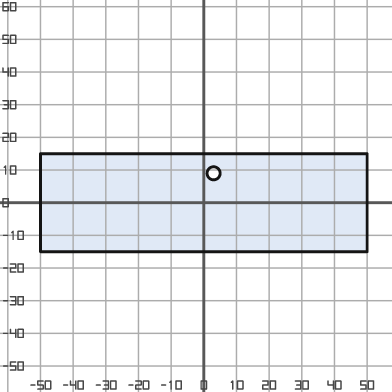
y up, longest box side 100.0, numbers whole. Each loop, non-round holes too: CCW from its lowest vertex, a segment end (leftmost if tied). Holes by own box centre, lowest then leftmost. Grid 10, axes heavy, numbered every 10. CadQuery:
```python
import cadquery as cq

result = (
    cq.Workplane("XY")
    .moveTo(-50.0, -15.0)
    .lineTo(50.0, -15.0)
    .lineTo(50.0, 15.0)
    .lineTo(-50.0, 15.0)
    .close()
    .moveTo(3.0, 9.0)
    .circle(2.0)
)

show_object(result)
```